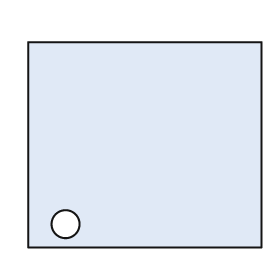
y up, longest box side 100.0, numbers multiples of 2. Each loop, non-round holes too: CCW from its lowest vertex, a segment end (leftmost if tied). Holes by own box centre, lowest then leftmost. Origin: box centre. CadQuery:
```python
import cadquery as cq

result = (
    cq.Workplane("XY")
    .moveTo(-50.0, -44.0)
    .lineTo(50.0, -44.0)
    .lineTo(50.0, 44.0)
    .lineTo(-50.0, 44.0)
    .close()
    .moveTo(-34.0, -34.0)
    .circle(6.0)
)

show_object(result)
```